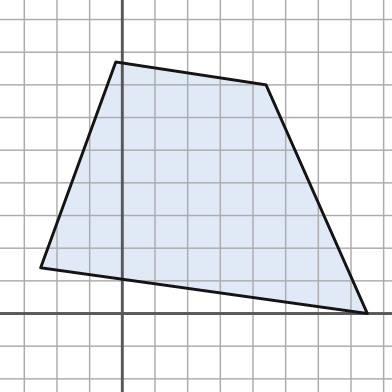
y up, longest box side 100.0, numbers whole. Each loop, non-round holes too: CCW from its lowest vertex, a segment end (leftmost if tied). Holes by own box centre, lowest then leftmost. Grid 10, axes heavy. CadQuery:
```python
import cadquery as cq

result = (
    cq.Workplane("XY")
    .moveTo(75.0, 0.0)
    .lineTo(44.0, 70.0)
    .lineTo(-2.0, 77.0)
    .lineTo(-25.0, 14.0)
    .close()
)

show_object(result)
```